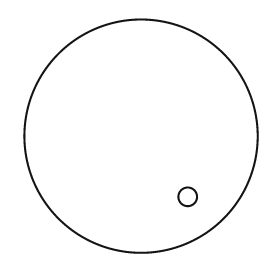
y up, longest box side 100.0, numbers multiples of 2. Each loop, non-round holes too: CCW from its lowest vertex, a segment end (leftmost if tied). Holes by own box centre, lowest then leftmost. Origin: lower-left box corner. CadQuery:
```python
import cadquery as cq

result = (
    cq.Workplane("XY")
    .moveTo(50.0, 50.0)
    .circle(50.0)
    .moveTo(70.0, 24.0)
    .circle(4.0)
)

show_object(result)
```